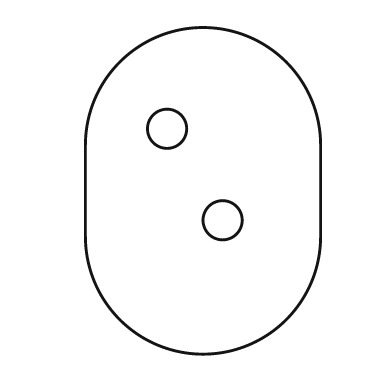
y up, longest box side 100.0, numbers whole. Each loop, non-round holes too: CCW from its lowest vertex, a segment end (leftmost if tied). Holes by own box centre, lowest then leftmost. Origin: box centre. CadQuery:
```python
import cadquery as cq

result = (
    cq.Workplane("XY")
    .moveTo(-36.0, -14.0)
    .threePointArc((0.0, -50.0), (36.0, -14.0))
    .lineTo(36.0, 14.0)
    .threePointArc((0.0, 50.0), (-36.0, 14.0))
    .close()
    .moveTo(6.0, -9.0)
    .circle(6.0)
    .moveTo(-11.0, 19.0)
    .circle(6.0)
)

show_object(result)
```